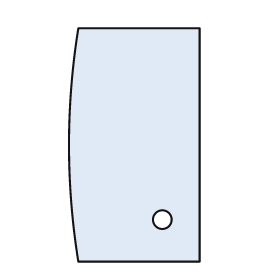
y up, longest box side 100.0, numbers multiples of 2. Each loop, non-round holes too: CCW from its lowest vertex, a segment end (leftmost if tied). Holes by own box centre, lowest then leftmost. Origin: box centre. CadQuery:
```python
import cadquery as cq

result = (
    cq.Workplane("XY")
    .moveTo(-24.0, -50.0)
    .lineTo(28.0, -50.0)
    .lineTo(28.0, 50.0)
    .lineTo(-24.0, 50.0)
    .threePointArc((-28.0, 0.0), (-24.0, -50.0))
    .close()
    .moveTo(12.0, -32.0)
    .circle(4.0)
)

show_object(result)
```